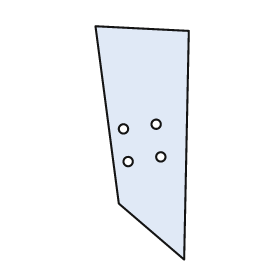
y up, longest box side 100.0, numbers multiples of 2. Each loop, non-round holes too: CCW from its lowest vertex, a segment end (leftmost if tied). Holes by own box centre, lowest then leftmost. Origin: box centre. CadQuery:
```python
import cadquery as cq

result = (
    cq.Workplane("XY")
    .moveTo(18.0, -50.0)
    .lineTo(20.0, 48.0)
    .lineTo(-20.0, 50.0)
    .lineTo(-10.0, -26.0)
    .close()
    .moveTo(-6.0, -8.0)
    .circle(2.0)
    .moveTo(8.0, -6.0)
    .circle(2.0)
    .moveTo(-8.0, 6.0)
    .circle(2.0)
    .moveTo(6.0, 8.0)
    .circle(2.0)
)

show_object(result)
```